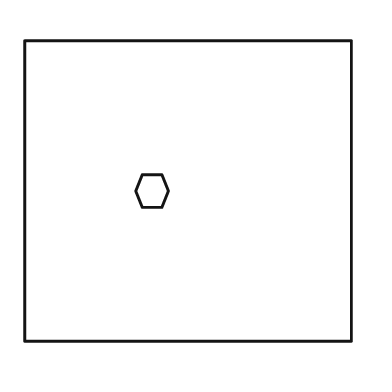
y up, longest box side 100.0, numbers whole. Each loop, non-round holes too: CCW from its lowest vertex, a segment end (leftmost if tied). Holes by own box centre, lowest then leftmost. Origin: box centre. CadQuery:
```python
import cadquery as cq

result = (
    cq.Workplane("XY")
    .moveTo(-50.0, -46.0)
    .lineTo(50.0, -46.0)
    .lineTo(50.0, 46.0)
    .lineTo(-50.0, 46.0)
    .close()
    .moveTo(-14.0, -5.0)
    .lineTo(-8.0, -5.0)
    .lineTo(-6.0, 0.0)
    .lineTo(-8.0, 5.0)
    .lineTo(-14.0, 5.0)
    .lineTo(-16.0, 0.0)
    .close()
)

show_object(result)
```